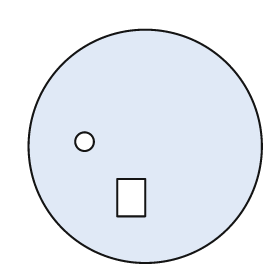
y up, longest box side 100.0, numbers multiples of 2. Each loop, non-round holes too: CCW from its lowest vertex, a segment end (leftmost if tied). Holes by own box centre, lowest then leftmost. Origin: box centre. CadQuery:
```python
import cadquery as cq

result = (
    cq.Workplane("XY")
    .moveTo(0.0, 0.0)
    .circle(50.0)
    .moveTo(-12.0, -30.0)
    .lineTo(0.0, -30.0)
    .lineTo(0.0, -14.0)
    .lineTo(-12.0, -14.0)
    .close()
    .moveTo(-26.0, 2.0)
    .circle(4.0)
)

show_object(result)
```